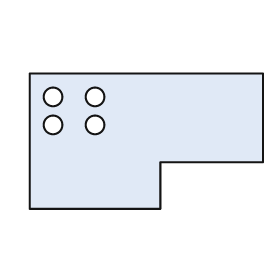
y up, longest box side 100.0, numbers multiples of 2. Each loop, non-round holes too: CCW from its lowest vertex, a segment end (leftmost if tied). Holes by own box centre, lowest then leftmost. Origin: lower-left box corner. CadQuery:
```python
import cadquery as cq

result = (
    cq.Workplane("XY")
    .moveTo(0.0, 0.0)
    .lineTo(56.0, 0.0)
    .lineTo(56.0, 20.0)
    .lineTo(100.0, 20.0)
    .lineTo(100.0, 58.0)
    .lineTo(0.0, 58.0)
    .close()
    .moveTo(10.0, 36.0)
    .circle(4.0)
    .moveTo(28.0, 36.0)
    .circle(4.0)
    .moveTo(10.0, 48.0)
    .circle(4.0)
    .moveTo(28.0, 48.0)
    .circle(4.0)
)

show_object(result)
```